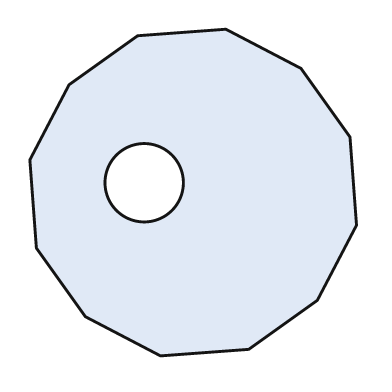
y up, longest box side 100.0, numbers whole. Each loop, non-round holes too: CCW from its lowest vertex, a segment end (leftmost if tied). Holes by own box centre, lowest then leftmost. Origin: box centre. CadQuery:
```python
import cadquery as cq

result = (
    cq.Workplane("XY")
    .moveTo(-10.0, -50.0)
    .lineTo(17.0, -48.0)
    .lineTo(38.0, -33.0)
    .lineTo(50.0, -10.0)
    .lineTo(48.0, 17.0)
    .lineTo(33.0, 38.0)
    .lineTo(10.0, 50.0)
    .lineTo(-17.0, 48.0)
    .lineTo(-38.0, 33.0)
    .lineTo(-50.0, 10.0)
    .lineTo(-48.0, -17.0)
    .lineTo(-33.0, -38.0)
    .close()
    .moveTo(-15.0, 3.0)
    .circle(12.0)
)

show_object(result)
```